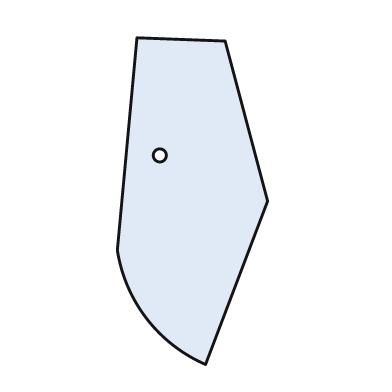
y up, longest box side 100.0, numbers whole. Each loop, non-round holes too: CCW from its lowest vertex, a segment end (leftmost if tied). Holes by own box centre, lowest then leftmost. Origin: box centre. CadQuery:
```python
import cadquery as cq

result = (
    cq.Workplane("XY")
    .moveTo(4.0, -50.0)
    .lineTo(23.0, 0.0)
    .lineTo(10.0, 49.0)
    .lineTo(-17.0, 50.0)
    .lineTo(-23.0, -15.0)
    .threePointArc((-14.0, -36.0), (4.0, -50.0))
    .close()
    .moveTo(-10.0, 14.0)
    .circle(2.0)
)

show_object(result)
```